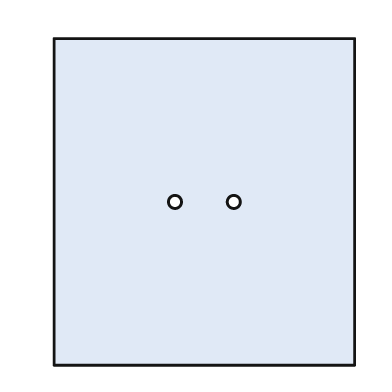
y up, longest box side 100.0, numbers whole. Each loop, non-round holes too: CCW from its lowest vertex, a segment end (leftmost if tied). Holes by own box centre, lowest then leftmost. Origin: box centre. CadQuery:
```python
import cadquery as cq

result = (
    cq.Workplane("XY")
    .moveTo(-46.0, -50.0)
    .lineTo(46.0, -50.0)
    .lineTo(46.0, 50.0)
    .lineTo(-46.0, 50.0)
    .close()
    .moveTo(-9.0, 0.0)
    .circle(2.0)
    .moveTo(9.0, 0.0)
    .circle(2.0)
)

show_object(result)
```